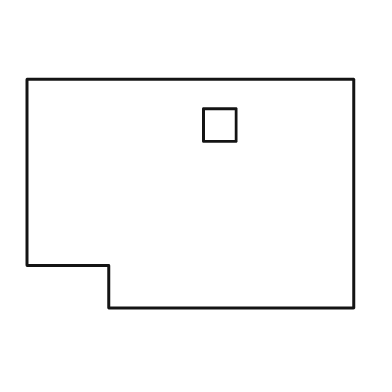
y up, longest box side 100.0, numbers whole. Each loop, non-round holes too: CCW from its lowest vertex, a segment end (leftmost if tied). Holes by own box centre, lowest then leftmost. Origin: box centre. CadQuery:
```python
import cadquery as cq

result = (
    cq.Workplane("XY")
    .moveTo(-25.0, -35.0)
    .lineTo(50.0, -35.0)
    .lineTo(50.0, 35.0)
    .lineTo(-50.0, 35.0)
    .lineTo(-50.0, -22.0)
    .lineTo(-25.0, -22.0)
    .close()
    .moveTo(4.0, 16.0)
    .lineTo(14.0, 16.0)
    .lineTo(14.0, 26.0)
    .lineTo(4.0, 26.0)
    .close()
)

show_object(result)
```